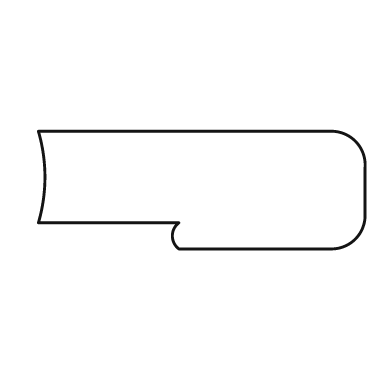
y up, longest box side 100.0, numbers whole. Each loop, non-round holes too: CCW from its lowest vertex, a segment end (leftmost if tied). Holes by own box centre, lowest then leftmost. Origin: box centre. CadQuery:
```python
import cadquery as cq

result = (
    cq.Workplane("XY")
    .moveTo(-7.0, -18.0)
    .lineTo(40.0, -18.0)
    .threePointArc((47.0, -15.0), (50.0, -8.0))
    .lineTo(50.0, 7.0)
    .threePointArc((47.0, 15.0), (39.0, 18.0))
    .lineTo(-50.0, 18.0)
    .threePointArc((-48.0, 4.0), (-50.0, -10.0))
    .lineTo(-7.0, -10.0)
    .threePointArc((-9.0, -14.0), (-7.0, -18.0))
    .close()
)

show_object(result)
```